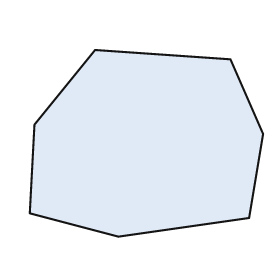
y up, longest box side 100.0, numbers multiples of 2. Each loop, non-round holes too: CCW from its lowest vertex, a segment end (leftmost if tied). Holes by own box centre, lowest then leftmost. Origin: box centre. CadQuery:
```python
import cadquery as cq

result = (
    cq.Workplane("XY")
    .moveTo(-12.0, -40.0)
    .lineTo(44.0, -32.0)
    .lineTo(50.0, 4.0)
    .lineTo(36.0, 36.0)
    .lineTo(-22.0, 40.0)
    .lineTo(-48.0, 8.0)
    .lineTo(-50.0, -30.0)
    .close()
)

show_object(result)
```